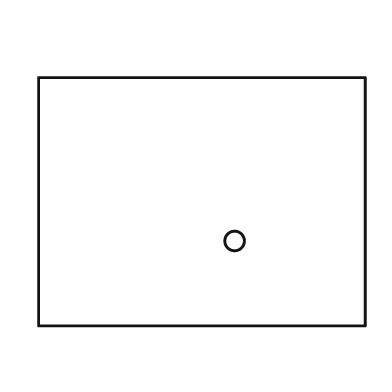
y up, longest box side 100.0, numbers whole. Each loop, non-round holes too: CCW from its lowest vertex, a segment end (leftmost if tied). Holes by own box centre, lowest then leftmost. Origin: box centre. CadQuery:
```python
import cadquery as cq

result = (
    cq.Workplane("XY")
    .moveTo(-50.0, -38.0)
    .lineTo(50.0, -38.0)
    .lineTo(50.0, 38.0)
    .lineTo(-50.0, 38.0)
    .close()
    .moveTo(10.0, -12.0)
    .circle(3.0)
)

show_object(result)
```